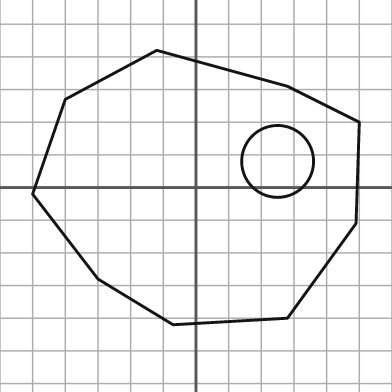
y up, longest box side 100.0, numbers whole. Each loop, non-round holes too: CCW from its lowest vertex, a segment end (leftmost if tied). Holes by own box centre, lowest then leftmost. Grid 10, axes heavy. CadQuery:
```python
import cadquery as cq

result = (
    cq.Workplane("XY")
    .moveTo(-7.0, -42.0)
    .lineTo(28.0, -40.0)
    .lineTo(49.0, -11.0)
    .lineTo(50.0, 20.0)
    .lineTo(28.0, 31.0)
    .lineTo(-12.0, 42.0)
    .lineTo(-40.0, 27.0)
    .lineTo(-50.0, -2.0)
    .lineTo(-30.0, -28.0)
    .close()
    .moveTo(25.0, 8.0)
    .circle(11.0)
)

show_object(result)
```